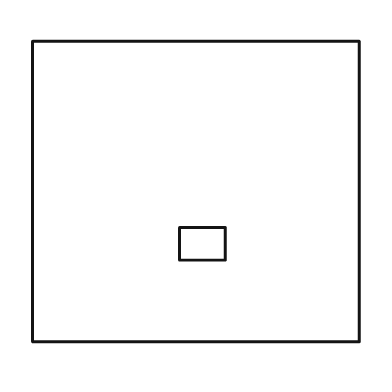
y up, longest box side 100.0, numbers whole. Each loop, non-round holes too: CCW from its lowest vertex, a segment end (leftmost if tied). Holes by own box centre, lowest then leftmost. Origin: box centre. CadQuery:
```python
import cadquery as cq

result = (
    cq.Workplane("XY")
    .moveTo(-50.0, -46.0)
    .lineTo(50.0, -46.0)
    .lineTo(50.0, 46.0)
    .lineTo(-50.0, 46.0)
    .close()
    .moveTo(-5.0, -21.0)
    .lineTo(9.0, -21.0)
    .lineTo(9.0, -11.0)
    .lineTo(-5.0, -11.0)
    .close()
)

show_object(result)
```